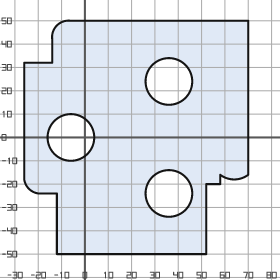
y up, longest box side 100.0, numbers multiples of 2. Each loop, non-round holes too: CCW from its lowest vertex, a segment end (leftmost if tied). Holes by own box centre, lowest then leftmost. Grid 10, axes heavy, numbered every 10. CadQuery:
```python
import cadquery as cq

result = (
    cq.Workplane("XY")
    .moveTo(-12.0, -50.0)
    .lineTo(52.0, -50.0)
    .lineTo(52.0, -20.0)
    .lineTo(58.0, -20.0)
    .lineTo(58.0, -16.0)
    .threePointArc((64.0, -18.0), (70.0, -16.0))
    .lineTo(70.0, 50.0)
    .lineTo(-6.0, 50.0)
    .threePointArc((-12.0, 48.0), (-14.0, 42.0))
    .lineTo(-14.0, 32.0)
    .lineTo(-26.0, 32.0)
    .lineTo(-26.0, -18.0)
    .threePointArc((-24.0, -22.0), (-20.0, -24.0))
    .lineTo(-12.0, -24.0)
    .close()
    .moveTo(36.0, -24.0)
    .circle(10.0)
    .moveTo(-6.0, 0.0)
    .circle(10.0)
    .moveTo(36.0, 24.0)
    .circle(10.0)
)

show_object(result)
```